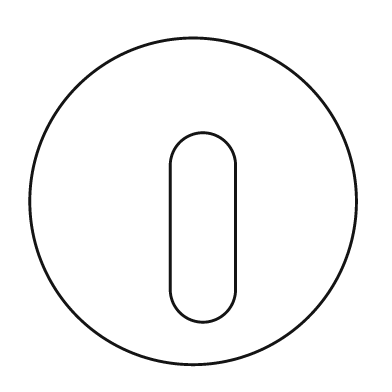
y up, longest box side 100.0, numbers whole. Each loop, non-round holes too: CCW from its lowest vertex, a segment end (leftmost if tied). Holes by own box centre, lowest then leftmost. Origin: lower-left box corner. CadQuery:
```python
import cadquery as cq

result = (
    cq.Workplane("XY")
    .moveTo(50.0, 50.0)
    .circle(50.0)
    .moveTo(43.0, 23.0)
    .threePointArc((53.0, 13.0), (63.0, 23.0))
    .lineTo(63.0, 61.0)
    .threePointArc((53.0, 71.0), (43.0, 61.0))
    .close()
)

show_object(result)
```